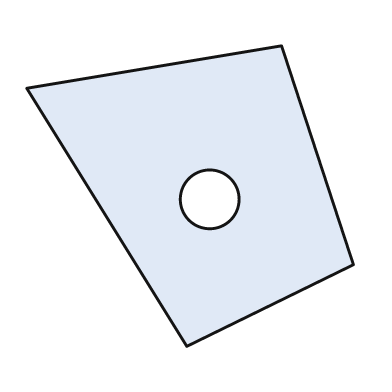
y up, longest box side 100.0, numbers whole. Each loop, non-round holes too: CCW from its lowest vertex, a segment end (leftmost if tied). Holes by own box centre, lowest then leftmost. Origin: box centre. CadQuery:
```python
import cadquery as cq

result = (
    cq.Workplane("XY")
    .moveTo(-1.0, -46.0)
    .lineTo(50.0, -21.0)
    .lineTo(28.0, 46.0)
    .lineTo(-50.0, 33.0)
    .close()
    .moveTo(6.0, -1.0)
    .circle(9.0)
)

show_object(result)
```